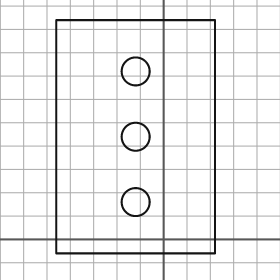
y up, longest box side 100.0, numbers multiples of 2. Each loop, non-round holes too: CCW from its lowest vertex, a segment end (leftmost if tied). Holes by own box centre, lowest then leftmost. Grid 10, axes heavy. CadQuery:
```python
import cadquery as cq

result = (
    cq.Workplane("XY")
    .moveTo(-46.0, -6.0)
    .lineTo(22.0, -6.0)
    .lineTo(22.0, 94.0)
    .lineTo(-46.0, 94.0)
    .close()
    .moveTo(-12.0, 16.0)
    .circle(6.0)
    .moveTo(-12.0, 44.0)
    .circle(6.0)
    .moveTo(-12.0, 72.0)
    .circle(6.0)
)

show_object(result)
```